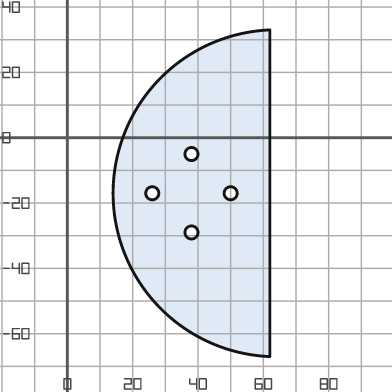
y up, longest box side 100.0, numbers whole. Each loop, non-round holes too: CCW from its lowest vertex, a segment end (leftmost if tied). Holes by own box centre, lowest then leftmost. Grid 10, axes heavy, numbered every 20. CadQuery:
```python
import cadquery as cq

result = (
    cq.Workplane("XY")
    .moveTo(62.0, -67.0)
    .lineTo(62.0, 33.0)
    .threePointArc((14.0, -17.0), (62.0, -67.0))
    .close()
    .moveTo(38.0, -29.0)
    .circle(2.0)
    .moveTo(26.0, -17.0)
    .circle(2.0)
    .moveTo(50.0, -17.0)
    .circle(2.0)
    .moveTo(38.0, -5.0)
    .circle(2.0)
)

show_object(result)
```